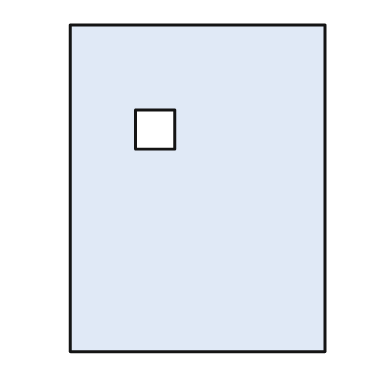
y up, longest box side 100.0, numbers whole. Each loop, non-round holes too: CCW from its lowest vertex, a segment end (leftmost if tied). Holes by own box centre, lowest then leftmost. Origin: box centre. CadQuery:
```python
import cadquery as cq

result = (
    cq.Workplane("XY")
    .moveTo(-39.0, -50.0)
    .lineTo(39.0, -50.0)
    .lineTo(39.0, 50.0)
    .lineTo(-39.0, 50.0)
    .close()
    .moveTo(-19.0, 12.0)
    .lineTo(-7.0, 12.0)
    .lineTo(-7.0, 24.0)
    .lineTo(-19.0, 24.0)
    .close()
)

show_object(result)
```